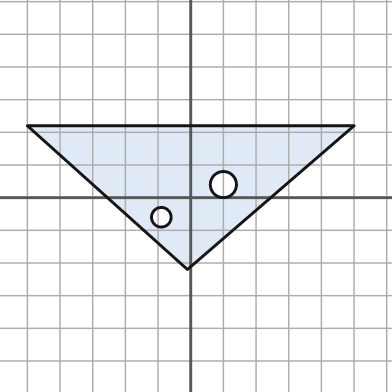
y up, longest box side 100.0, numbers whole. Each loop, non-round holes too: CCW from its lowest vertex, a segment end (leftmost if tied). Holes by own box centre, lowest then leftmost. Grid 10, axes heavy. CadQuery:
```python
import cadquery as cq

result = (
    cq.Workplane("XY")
    .moveTo(-1.0, -22.0)
    .lineTo(50.0, 22.0)
    .lineTo(-50.0, 22.0)
    .close()
    .moveTo(-9.0, -6.0)
    .circle(3.0)
    .moveTo(10.0, 4.0)
    .circle(4.0)
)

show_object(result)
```